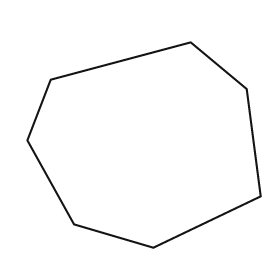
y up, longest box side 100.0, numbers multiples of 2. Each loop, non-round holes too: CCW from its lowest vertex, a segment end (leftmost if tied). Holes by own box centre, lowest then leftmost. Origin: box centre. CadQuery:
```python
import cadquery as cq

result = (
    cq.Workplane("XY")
    .moveTo(4.0, -44.0)
    .lineTo(50.0, -22.0)
    .lineTo(44.0, 24.0)
    .lineTo(20.0, 44.0)
    .lineTo(-40.0, 28.0)
    .lineTo(-50.0, 2.0)
    .lineTo(-30.0, -34.0)
    .close()
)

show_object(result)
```